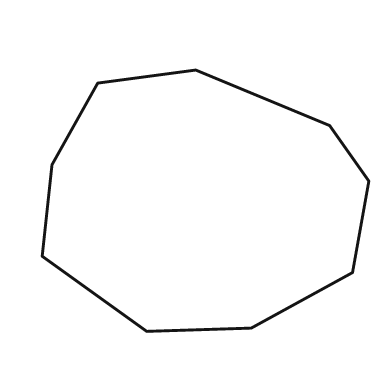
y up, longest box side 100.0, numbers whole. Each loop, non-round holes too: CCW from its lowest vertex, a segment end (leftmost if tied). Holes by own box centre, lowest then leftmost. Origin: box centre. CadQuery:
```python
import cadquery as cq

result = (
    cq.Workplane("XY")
    .moveTo(-18.0, -40.0)
    .lineTo(14.0, -39.0)
    .lineTo(45.0, -22.0)
    .lineTo(50.0, 6.0)
    .lineTo(38.0, 23.0)
    .lineTo(-3.0, 40.0)
    .lineTo(-33.0, 36.0)
    .lineTo(-47.0, 11.0)
    .lineTo(-50.0, -17.0)
    .close()
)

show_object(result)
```